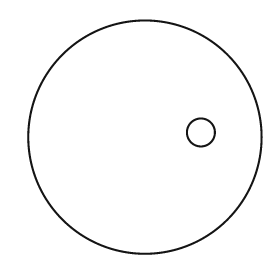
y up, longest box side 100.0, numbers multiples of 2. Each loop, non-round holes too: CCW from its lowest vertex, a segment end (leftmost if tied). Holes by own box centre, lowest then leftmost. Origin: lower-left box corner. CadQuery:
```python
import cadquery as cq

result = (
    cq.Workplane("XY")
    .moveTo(50.0, 50.0)
    .circle(50.0)
    .moveTo(74.0, 52.0)
    .circle(6.0)
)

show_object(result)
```